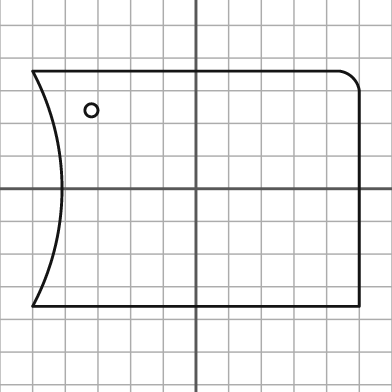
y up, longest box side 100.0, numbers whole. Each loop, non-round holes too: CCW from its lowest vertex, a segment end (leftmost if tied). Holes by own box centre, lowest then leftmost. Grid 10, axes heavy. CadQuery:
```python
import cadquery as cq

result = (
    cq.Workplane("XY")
    .moveTo(-50.0, -36.0)
    .lineTo(50.0, -36.0)
    .lineTo(50.0, 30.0)
    .threePointArc((48.0, 34.0), (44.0, 36.0))
    .lineTo(-50.0, 36.0)
    .threePointArc((-41.0, 0.0), (-50.0, -36.0))
    .close()
    .moveTo(-32.0, 24.0)
    .circle(2.0)
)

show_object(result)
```